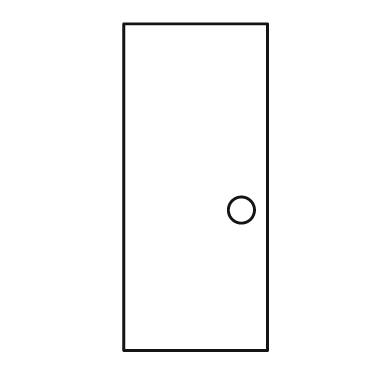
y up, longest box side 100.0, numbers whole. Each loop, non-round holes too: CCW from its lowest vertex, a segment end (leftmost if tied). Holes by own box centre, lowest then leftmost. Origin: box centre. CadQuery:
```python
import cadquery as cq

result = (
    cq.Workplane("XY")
    .moveTo(-22.0, -50.0)
    .lineTo(22.0, -50.0)
    .lineTo(22.0, 50.0)
    .lineTo(-22.0, 50.0)
    .close()
    .moveTo(14.0, -7.0)
    .circle(4.0)
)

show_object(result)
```